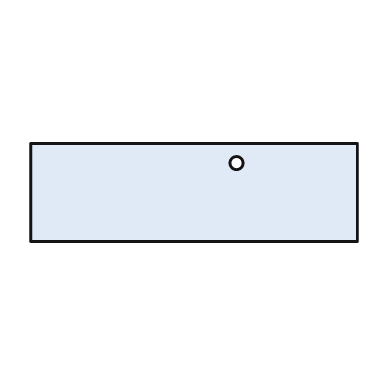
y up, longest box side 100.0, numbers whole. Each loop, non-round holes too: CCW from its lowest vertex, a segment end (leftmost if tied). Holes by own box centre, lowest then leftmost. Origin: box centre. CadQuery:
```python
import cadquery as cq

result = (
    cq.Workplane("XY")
    .moveTo(-50.0, -15.0)
    .lineTo(50.0, -15.0)
    .lineTo(50.0, 15.0)
    .lineTo(-50.0, 15.0)
    .close()
    .moveTo(13.0, 9.0)
    .circle(2.0)
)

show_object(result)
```